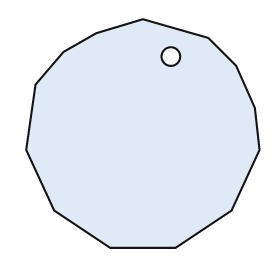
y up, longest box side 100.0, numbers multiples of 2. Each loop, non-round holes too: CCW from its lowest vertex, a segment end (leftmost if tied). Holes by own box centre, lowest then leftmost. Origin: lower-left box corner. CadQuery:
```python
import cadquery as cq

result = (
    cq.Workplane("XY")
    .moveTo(36.0, 0.0)
    .lineTo(64.0, 0.0)
    .lineTo(88.0, 16.0)
    .lineTo(100.0, 42.0)
    .lineTo(98.0, 60.0)
    .lineTo(90.0, 78.0)
    .lineTo(78.0, 90.0)
    .lineTo(50.0, 98.0)
    .lineTo(30.0, 92.0)
    .lineTo(16.0, 84.0)
    .lineTo(4.0, 70.0)
    .lineTo(0.0, 42.0)
    .lineTo(12.0, 16.0)
    .close()
    .moveTo(62.0, 82.0)
    .circle(4.0)
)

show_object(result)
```